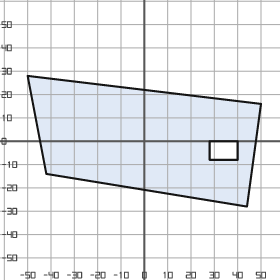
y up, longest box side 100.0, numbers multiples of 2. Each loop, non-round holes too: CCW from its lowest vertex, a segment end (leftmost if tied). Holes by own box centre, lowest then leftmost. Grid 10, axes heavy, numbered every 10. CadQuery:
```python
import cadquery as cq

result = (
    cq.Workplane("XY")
    .moveTo(44.0, -28.0)
    .lineTo(50.0, 16.0)
    .lineTo(-50.0, 28.0)
    .lineTo(-42.0, -14.0)
    .close()
    .moveTo(28.0, -8.0)
    .lineTo(40.0, -8.0)
    .lineTo(40.0, 0.0)
    .lineTo(28.0, 0.0)
    .close()
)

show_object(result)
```